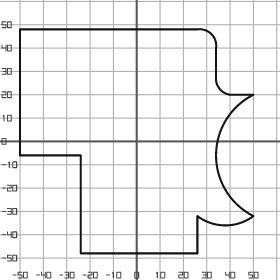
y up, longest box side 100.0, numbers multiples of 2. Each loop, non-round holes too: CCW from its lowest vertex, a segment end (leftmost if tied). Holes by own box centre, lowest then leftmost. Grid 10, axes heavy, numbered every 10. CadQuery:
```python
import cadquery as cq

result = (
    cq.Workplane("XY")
    .moveTo(-24.0, -48.0)
    .lineTo(26.0, -48.0)
    .lineTo(26.0, -32.0)
    .threePointArc((38.0, -36.0), (50.0, -32.0))
    .threePointArc((34.0, -6.0), (50.0, 20.0))
    .lineTo(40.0, 20.0)
    .threePointArc((36.0, 22.0), (34.0, 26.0))
    .lineTo(34.0, 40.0)
    .threePointArc((32.0, 46.0), (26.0, 48.0))
    .lineTo(-50.0, 48.0)
    .lineTo(-50.0, -6.0)
    .lineTo(-24.0, -6.0)
    .close()
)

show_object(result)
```